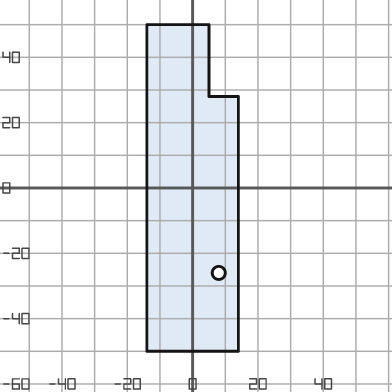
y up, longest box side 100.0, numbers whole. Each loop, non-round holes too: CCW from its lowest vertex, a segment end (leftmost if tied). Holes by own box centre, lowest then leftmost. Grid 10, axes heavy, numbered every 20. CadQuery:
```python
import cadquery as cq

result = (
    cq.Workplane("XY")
    .moveTo(-14.0, -50.0)
    .lineTo(14.0, -50.0)
    .lineTo(14.0, 28.0)
    .lineTo(5.0, 28.0)
    .lineTo(5.0, 50.0)
    .lineTo(-14.0, 50.0)
    .close()
    .moveTo(8.0, -26.0)
    .circle(2.0)
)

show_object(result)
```